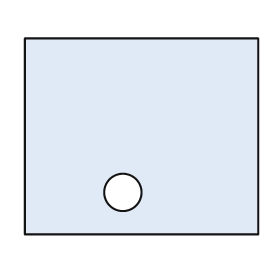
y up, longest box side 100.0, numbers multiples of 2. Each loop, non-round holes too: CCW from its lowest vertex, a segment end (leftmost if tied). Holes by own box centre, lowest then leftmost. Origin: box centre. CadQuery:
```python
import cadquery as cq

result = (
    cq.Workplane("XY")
    .moveTo(-50.0, -42.0)
    .lineTo(50.0, -42.0)
    .lineTo(50.0, 42.0)
    .lineTo(-50.0, 42.0)
    .close()
    .moveTo(-8.0, -24.0)
    .circle(8.0)
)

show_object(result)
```